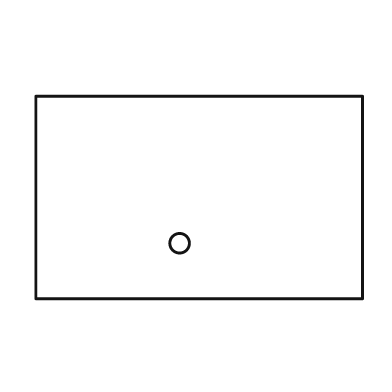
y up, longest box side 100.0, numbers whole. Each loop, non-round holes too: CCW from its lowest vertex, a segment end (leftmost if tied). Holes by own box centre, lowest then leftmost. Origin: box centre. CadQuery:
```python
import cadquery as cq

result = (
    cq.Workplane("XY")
    .moveTo(-50.0, -31.0)
    .lineTo(50.0, -31.0)
    .lineTo(50.0, 31.0)
    .lineTo(-50.0, 31.0)
    .close()
    .moveTo(-6.0, -14.0)
    .circle(3.0)
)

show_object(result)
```